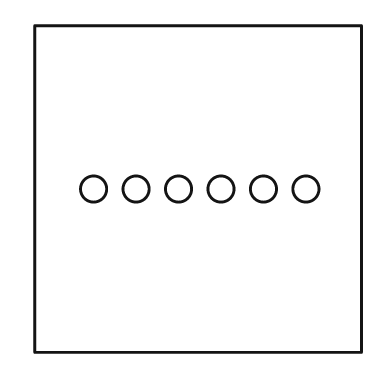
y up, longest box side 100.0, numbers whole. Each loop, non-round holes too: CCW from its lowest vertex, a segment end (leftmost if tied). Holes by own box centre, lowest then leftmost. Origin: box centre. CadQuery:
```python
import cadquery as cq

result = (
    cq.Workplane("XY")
    .moveTo(-50.0, -50.0)
    .lineTo(50.0, -50.0)
    .lineTo(50.0, 50.0)
    .lineTo(-50.0, 50.0)
    .close()
    .moveTo(-32.0, 0.0)
    .circle(4.0)
    .moveTo(-19.0, 0.0)
    .circle(4.0)
    .moveTo(-6.0, 0.0)
    .circle(4.0)
    .moveTo(7.0, 0.0)
    .circle(4.0)
    .moveTo(20.0, 0.0)
    .circle(4.0)
    .moveTo(33.0, 0.0)
    .circle(4.0)
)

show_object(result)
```